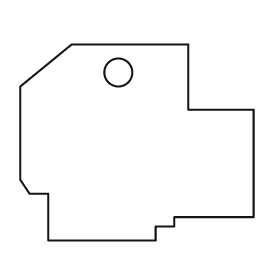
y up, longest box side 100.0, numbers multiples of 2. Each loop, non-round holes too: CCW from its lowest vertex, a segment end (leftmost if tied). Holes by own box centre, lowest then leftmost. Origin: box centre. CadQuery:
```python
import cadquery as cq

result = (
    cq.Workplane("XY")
    .moveTo(-38.0, -42.0)
    .lineTo(8.0, -42.0)
    .lineTo(8.0, -36.0)
    .lineTo(16.0, -36.0)
    .lineTo(16.0, -32.0)
    .lineTo(50.0, -32.0)
    .lineTo(50.0, 14.0)
    .lineTo(22.0, 14.0)
    .lineTo(22.0, 42.0)
    .lineTo(-28.0, 42.0)
    .lineTo(-50.0, 24.0)
    .lineTo(-50.0, -16.0)
    .lineTo(-46.0, -22.0)
    .lineTo(-38.0, -22.0)
    .close()
    .moveTo(-8.0, 30.0)
    .circle(6.0)
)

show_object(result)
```